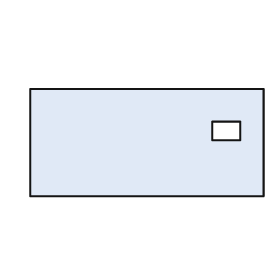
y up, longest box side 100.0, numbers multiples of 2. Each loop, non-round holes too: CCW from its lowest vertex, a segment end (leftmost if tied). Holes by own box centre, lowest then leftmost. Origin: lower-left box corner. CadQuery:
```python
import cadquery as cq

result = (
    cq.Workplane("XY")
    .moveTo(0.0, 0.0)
    .lineTo(100.0, 0.0)
    .lineTo(100.0, 46.0)
    .lineTo(0.0, 46.0)
    .close()
    .moveTo(78.0, 24.0)
    .lineTo(90.0, 24.0)
    .lineTo(90.0, 32.0)
    .lineTo(78.0, 32.0)
    .close()
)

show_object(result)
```